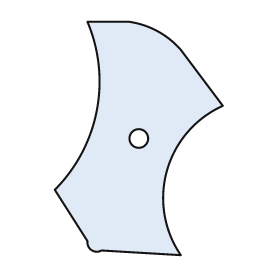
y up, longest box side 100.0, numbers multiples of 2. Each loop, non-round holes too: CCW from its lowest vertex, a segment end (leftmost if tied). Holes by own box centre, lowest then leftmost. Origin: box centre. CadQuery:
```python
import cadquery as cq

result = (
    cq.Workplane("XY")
    .moveTo(18.0, -50.0)
    .threePointArc((12.0, -14.0), (36.0, 14.0))
    .lineTo(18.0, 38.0)
    .threePointArc((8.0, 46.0), (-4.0, 50.0))
    .lineTo(-22.0, 50.0)
    .threePointArc((-18.0, 12.0), (-36.0, -22.0))
    .lineTo(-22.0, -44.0)
    .threePointArc((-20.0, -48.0), (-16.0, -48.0))
    .close()
    .moveTo(0.0, 0.0)
    .circle(4.0)
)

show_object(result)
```